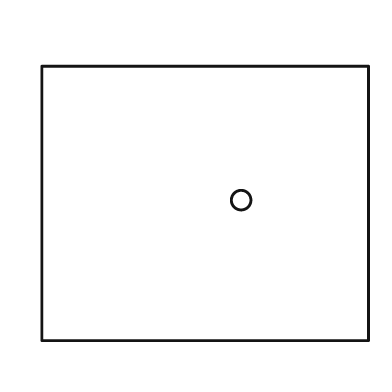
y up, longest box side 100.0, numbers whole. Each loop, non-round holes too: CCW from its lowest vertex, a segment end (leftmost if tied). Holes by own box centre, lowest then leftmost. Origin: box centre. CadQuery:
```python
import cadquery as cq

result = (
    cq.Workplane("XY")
    .moveTo(-50.0, -42.0)
    .lineTo(50.0, -42.0)
    .lineTo(50.0, 42.0)
    .lineTo(-50.0, 42.0)
    .close()
    .moveTo(11.0, 1.0)
    .circle(3.0)
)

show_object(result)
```